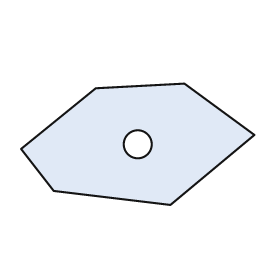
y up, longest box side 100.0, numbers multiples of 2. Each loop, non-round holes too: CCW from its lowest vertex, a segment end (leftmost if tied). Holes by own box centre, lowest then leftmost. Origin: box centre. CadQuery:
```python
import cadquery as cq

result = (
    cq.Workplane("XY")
    .moveTo(14.0, -26.0)
    .lineTo(50.0, 4.0)
    .lineTo(20.0, 26.0)
    .lineTo(-18.0, 24.0)
    .lineTo(-50.0, -2.0)
    .lineTo(-36.0, -20.0)
    .close()
    .moveTo(0.0, 0.0)
    .circle(6.0)
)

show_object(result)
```